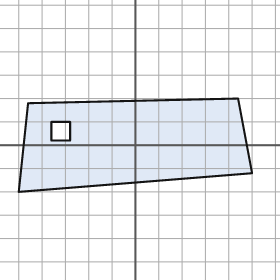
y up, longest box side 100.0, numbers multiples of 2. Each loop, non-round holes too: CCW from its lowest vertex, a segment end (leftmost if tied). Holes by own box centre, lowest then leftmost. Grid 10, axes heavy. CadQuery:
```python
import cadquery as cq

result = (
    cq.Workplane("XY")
    .moveTo(-50.0, -20.0)
    .lineTo(50.0, -12.0)
    .lineTo(44.0, 20.0)
    .lineTo(-46.0, 18.0)
    .close()
    .moveTo(-36.0, 2.0)
    .lineTo(-28.0, 2.0)
    .lineTo(-28.0, 10.0)
    .lineTo(-36.0, 10.0)
    .close()
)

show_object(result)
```